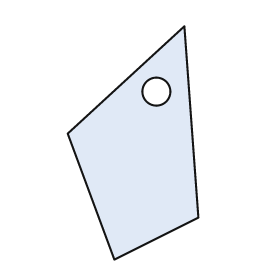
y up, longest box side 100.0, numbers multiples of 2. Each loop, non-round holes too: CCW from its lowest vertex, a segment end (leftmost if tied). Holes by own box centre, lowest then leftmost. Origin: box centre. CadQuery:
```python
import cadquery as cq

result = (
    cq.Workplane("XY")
    .moveTo(-8.0, -50.0)
    .lineTo(28.0, -32.0)
    .lineTo(22.0, 50.0)
    .lineTo(-28.0, 4.0)
    .close()
    .moveTo(10.0, 22.0)
    .circle(6.0)
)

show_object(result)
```